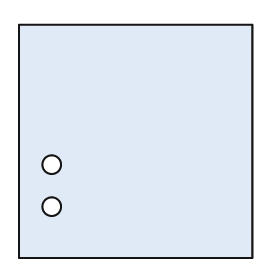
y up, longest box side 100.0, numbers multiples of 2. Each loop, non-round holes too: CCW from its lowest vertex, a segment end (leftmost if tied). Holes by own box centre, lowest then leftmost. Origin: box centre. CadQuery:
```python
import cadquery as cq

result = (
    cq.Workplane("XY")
    .moveTo(-50.0, -50.0)
    .lineTo(50.0, -50.0)
    .lineTo(50.0, 50.0)
    .lineTo(-50.0, 50.0)
    .close()
    .moveTo(-36.0, -28.0)
    .circle(4.0)
    .moveTo(-36.0, -10.0)
    .circle(4.0)
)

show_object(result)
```